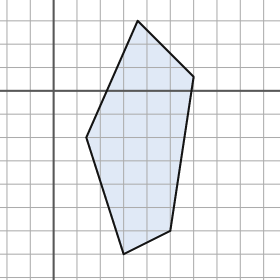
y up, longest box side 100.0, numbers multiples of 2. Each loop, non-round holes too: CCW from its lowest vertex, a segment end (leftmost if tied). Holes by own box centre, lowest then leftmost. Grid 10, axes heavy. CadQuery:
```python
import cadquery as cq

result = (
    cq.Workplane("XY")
    .moveTo(30.0, -70.0)
    .lineTo(50.0, -60.0)
    .lineTo(60.0, 6.0)
    .lineTo(36.0, 30.0)
    .lineTo(14.0, -20.0)
    .close()
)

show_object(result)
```